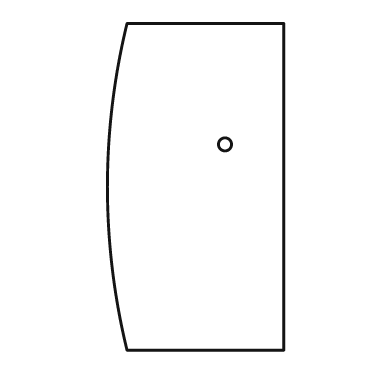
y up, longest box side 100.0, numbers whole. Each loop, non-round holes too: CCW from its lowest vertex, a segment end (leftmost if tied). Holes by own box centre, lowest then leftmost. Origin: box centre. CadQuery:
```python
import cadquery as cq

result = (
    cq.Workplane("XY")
    .moveTo(-21.0, -50.0)
    .lineTo(27.0, -50.0)
    .lineTo(27.0, 50.0)
    .lineTo(-21.0, 50.0)
    .threePointArc((-27.0, 0.0), (-21.0, -50.0))
    .close()
    .moveTo(9.0, 13.0)
    .circle(2.0)
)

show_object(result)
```